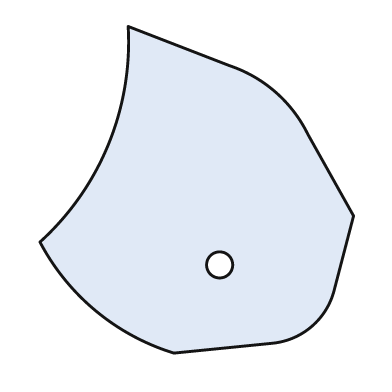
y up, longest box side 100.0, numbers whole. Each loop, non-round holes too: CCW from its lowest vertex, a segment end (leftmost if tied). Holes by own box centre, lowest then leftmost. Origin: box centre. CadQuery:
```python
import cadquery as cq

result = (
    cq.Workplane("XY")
    .moveTo(-7.0, -50.0)
    .lineTo(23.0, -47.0)
    .threePointArc((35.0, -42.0), (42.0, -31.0))
    .lineTo(48.0, -8.0)
    .lineTo(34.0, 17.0)
    .threePointArc((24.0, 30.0), (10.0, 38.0))
    .lineTo(-21.0, 50.0)
    .threePointArc((-27.0, 14.0), (-48.0, -16.0))
    .threePointArc((-31.0, -37.0), (-7.0, -50.0))
    .close()
    .moveTo(7.0, -23.0)
    .circle(4.0)
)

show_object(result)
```